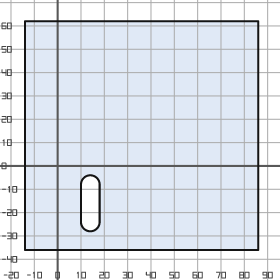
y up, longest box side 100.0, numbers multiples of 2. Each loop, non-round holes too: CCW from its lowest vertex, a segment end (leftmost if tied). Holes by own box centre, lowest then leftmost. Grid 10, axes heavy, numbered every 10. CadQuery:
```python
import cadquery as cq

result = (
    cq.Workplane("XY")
    .moveTo(-14.0, -36.0)
    .lineTo(86.0, -36.0)
    .lineTo(86.0, 62.0)
    .lineTo(-14.0, 62.0)
    .close()
    .moveTo(10.0, -24.0)
    .threePointArc((14.0, -28.0), (18.0, -24.0))
    .lineTo(18.0, -8.0)
    .threePointArc((14.0, -4.0), (10.0, -8.0))
    .close()
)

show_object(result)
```